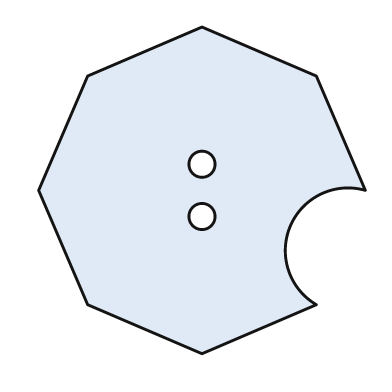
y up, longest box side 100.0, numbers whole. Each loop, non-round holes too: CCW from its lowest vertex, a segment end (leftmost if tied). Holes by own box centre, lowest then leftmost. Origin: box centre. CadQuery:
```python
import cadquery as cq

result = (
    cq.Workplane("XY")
    .moveTo(0.0, -50.0)
    .lineTo(35.0, -35.0)
    .threePointArc((27.0, -11.0), (50.0, 0.0))
    .lineTo(35.0, 35.0)
    .lineTo(0.0, 50.0)
    .lineTo(-35.0, 35.0)
    .lineTo(-50.0, 0.0)
    .lineTo(-35.0, -35.0)
    .close()
    .moveTo(0.0, -8.0)
    .circle(4.0)
    .moveTo(0.0, 8.0)
    .circle(4.0)
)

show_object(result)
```